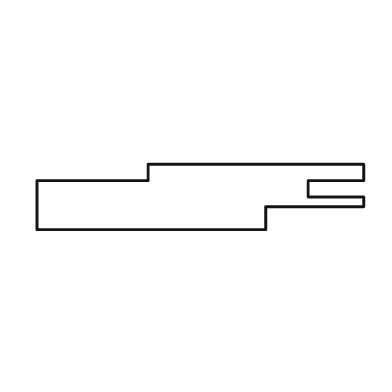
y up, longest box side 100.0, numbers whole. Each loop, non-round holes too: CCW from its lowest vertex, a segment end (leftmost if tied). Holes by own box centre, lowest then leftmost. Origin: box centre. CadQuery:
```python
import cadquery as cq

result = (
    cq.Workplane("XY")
    .moveTo(-50.0, -10.0)
    .lineTo(20.0, -10.0)
    .lineTo(20.0, -3.0)
    .lineTo(50.0, -3.0)
    .lineTo(50.0, 0.0)
    .lineTo(33.0, 0.0)
    .lineTo(33.0, 5.0)
    .lineTo(50.0, 5.0)
    .lineTo(50.0, 10.0)
    .lineTo(-16.0, 10.0)
    .lineTo(-16.0, 5.0)
    .lineTo(-50.0, 5.0)
    .close()
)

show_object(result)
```